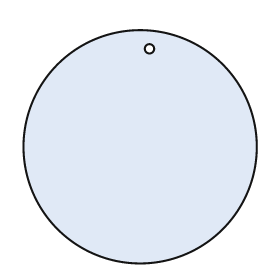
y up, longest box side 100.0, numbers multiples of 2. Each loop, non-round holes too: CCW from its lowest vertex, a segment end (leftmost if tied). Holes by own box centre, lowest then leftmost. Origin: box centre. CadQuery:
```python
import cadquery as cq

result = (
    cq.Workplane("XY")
    .moveTo(0.0, 0.0)
    .circle(50.0)
    .moveTo(4.0, 42.0)
    .circle(2.0)
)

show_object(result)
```